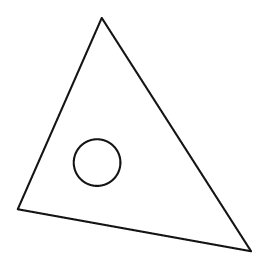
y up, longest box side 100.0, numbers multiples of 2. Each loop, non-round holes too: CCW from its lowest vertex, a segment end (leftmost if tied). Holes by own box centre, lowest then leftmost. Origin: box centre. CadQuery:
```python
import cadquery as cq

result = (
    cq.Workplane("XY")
    .moveTo(50.0, -50.0)
    .lineTo(-14.0, 50.0)
    .lineTo(-50.0, -32.0)
    .close()
    .moveTo(-16.0, -12.0)
    .circle(10.0)
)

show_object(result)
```